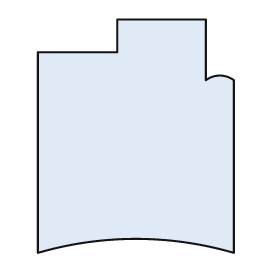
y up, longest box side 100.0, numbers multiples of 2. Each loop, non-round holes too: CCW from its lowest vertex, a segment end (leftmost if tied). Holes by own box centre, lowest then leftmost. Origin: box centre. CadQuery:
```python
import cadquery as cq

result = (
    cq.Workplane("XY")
    .moveTo(-42.0, -50.0)
    .threePointArc((0.0, -44.0), (42.0, -50.0))
    .lineTo(42.0, 24.0)
    .threePointArc((36.0, 26.0), (30.0, 24.0))
    .lineTo(30.0, 50.0)
    .lineTo(-8.0, 50.0)
    .lineTo(-8.0, 36.0)
    .lineTo(-42.0, 36.0)
    .close()
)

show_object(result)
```